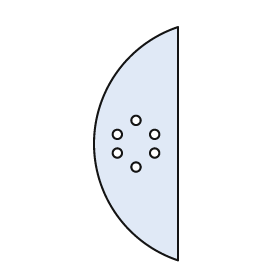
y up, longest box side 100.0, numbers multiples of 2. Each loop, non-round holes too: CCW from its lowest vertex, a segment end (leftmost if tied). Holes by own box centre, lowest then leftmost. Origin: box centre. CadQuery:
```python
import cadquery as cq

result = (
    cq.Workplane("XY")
    .moveTo(18.0, -50.0)
    .lineTo(18.0, 50.0)
    .threePointArc((-18.0, 0.0), (18.0, -50.0))
    .close()
    .moveTo(0.0, -10.0)
    .circle(2.0)
    .moveTo(-8.0, -4.0)
    .circle(2.0)
    .moveTo(8.0, -4.0)
    .circle(2.0)
    .moveTo(-8.0, 4.0)
    .circle(2.0)
    .moveTo(8.0, 4.0)
    .circle(2.0)
    .moveTo(0.0, 10.0)
    .circle(2.0)
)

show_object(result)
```